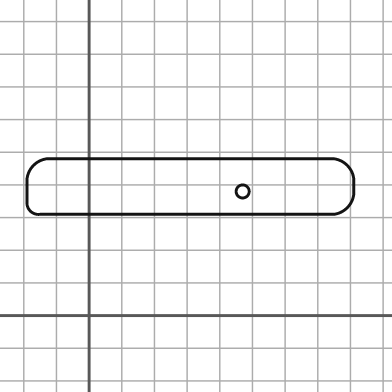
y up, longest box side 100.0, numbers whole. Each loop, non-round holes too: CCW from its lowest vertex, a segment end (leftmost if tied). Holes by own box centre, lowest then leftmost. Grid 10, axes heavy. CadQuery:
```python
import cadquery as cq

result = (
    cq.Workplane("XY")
    .moveTo(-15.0, 31.0)
    .lineTo(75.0, 31.0)
    .threePointArc((79.0, 33.0), (81.0, 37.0))
    .lineTo(81.0, 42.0)
    .threePointArc((79.0, 46.0), (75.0, 48.0))
    .lineTo(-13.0, 48.0)
    .threePointArc((-17.0, 46.0), (-19.0, 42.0))
    .lineTo(-19.0, 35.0)
    .threePointArc((-18.0, 32.0), (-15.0, 31.0))
    .close()
    .moveTo(47.0, 38.0)
    .circle(2.0)
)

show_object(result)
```